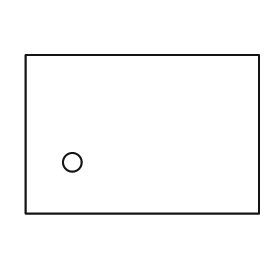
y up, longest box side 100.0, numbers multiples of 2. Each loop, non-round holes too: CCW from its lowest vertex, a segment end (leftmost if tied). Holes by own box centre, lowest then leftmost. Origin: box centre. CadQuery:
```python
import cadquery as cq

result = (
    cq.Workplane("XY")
    .moveTo(-50.0, -34.0)
    .lineTo(50.0, -34.0)
    .lineTo(50.0, 34.0)
    .lineTo(-50.0, 34.0)
    .close()
    .moveTo(-30.0, -12.0)
    .circle(4.0)
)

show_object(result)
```